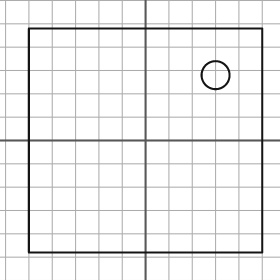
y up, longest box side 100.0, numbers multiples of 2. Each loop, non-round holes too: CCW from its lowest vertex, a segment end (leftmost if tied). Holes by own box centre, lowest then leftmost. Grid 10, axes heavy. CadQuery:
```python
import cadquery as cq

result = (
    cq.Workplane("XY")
    .moveTo(-50.0, -48.0)
    .lineTo(50.0, -48.0)
    .lineTo(50.0, 48.0)
    .lineTo(-50.0, 48.0)
    .close()
    .moveTo(30.0, 28.0)
    .circle(6.0)
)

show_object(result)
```